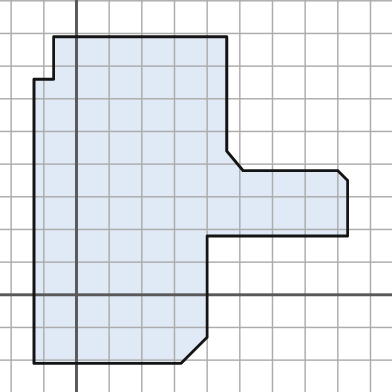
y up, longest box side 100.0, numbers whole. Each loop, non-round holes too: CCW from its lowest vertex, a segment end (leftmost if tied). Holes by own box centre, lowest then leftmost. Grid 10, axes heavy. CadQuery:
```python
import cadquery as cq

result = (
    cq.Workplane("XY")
    .moveTo(-13.0, -21.0)
    .lineTo(32.0, -21.0)
    .lineTo(40.0, -13.0)
    .lineTo(40.0, 18.0)
    .lineTo(83.0, 18.0)
    .lineTo(83.0, 35.0)
    .lineTo(80.0, 38.0)
    .lineTo(51.0, 38.0)
    .lineTo(46.0, 44.0)
    .lineTo(46.0, 79.0)
    .lineTo(-7.0, 79.0)
    .lineTo(-7.0, 66.0)
    .lineTo(-13.0, 66.0)
    .close()
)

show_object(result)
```